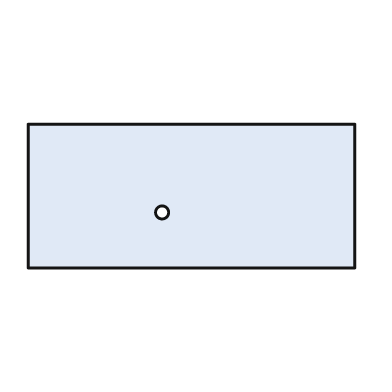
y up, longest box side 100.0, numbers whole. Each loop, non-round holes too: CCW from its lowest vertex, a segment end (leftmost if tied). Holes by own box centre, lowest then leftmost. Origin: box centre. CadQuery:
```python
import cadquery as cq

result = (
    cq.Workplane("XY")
    .moveTo(-50.0, -22.0)
    .lineTo(50.0, -22.0)
    .lineTo(50.0, 22.0)
    .lineTo(-50.0, 22.0)
    .close()
    .moveTo(-9.0, -5.0)
    .circle(2.0)
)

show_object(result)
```